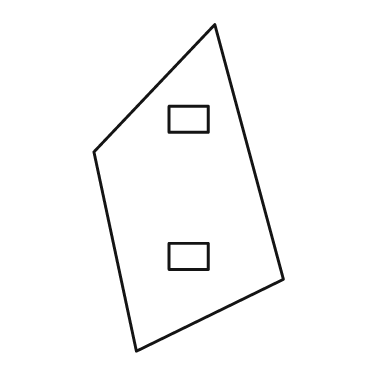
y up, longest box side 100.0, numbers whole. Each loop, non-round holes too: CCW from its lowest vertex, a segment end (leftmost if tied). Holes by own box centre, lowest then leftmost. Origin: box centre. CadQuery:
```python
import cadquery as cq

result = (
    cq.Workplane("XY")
    .moveTo(-16.0, -50.0)
    .lineTo(29.0, -28.0)
    .lineTo(8.0, 50.0)
    .lineTo(-29.0, 11.0)
    .close()
    .moveTo(-6.0, -25.0)
    .lineTo(6.0, -25.0)
    .lineTo(6.0, -17.0)
    .lineTo(-6.0, -17.0)
    .close()
    .moveTo(-6.0, 17.0)
    .lineTo(6.0, 17.0)
    .lineTo(6.0, 25.0)
    .lineTo(-6.0, 25.0)
    .close()
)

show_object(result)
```